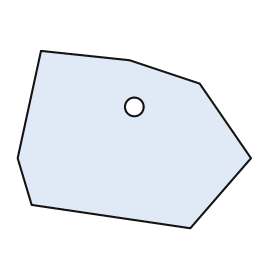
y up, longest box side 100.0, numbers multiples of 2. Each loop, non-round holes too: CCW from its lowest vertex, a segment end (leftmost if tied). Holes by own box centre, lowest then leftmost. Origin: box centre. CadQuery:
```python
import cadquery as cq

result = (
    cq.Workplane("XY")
    .moveTo(24.0, -38.0)
    .lineTo(50.0, -8.0)
    .lineTo(28.0, 24.0)
    .lineTo(-2.0, 34.0)
    .lineTo(-40.0, 38.0)
    .lineTo(-50.0, -8.0)
    .lineTo(-44.0, -28.0)
    .close()
    .moveTo(0.0, 14.0)
    .circle(4.0)
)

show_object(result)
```